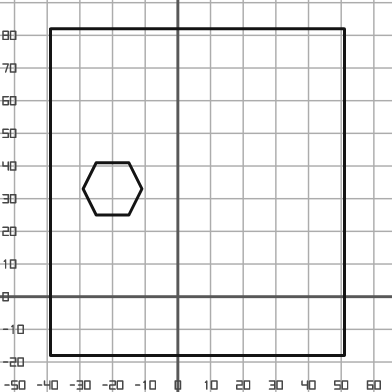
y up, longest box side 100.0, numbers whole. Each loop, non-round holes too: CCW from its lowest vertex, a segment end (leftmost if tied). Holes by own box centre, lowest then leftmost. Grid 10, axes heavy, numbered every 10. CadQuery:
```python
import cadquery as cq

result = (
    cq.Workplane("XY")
    .moveTo(-39.0, -18.0)
    .lineTo(51.0, -18.0)
    .lineTo(51.0, 82.0)
    .lineTo(-39.0, 82.0)
    .close()
    .moveTo(-25.0, 25.0)
    .lineTo(-15.0, 25.0)
    .lineTo(-11.0, 33.0)
    .lineTo(-15.0, 41.0)
    .lineTo(-25.0, 41.0)
    .lineTo(-29.0, 33.0)
    .close()
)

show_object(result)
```